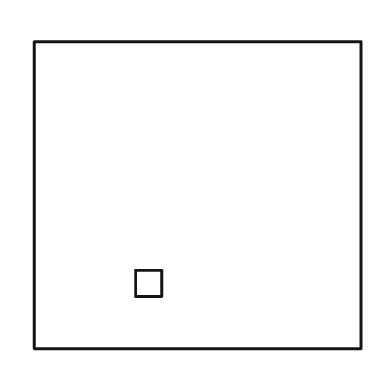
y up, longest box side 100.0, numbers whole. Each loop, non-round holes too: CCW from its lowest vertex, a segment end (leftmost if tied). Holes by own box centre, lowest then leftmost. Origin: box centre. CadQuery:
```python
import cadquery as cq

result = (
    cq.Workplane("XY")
    .moveTo(-50.0, -47.0)
    .lineTo(50.0, -47.0)
    .lineTo(50.0, 47.0)
    .lineTo(-50.0, 47.0)
    .close()
    .moveTo(-19.0, -31.0)
    .lineTo(-11.0, -31.0)
    .lineTo(-11.0, -23.0)
    .lineTo(-19.0, -23.0)
    .close()
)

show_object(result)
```